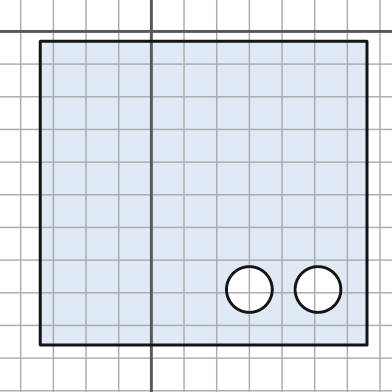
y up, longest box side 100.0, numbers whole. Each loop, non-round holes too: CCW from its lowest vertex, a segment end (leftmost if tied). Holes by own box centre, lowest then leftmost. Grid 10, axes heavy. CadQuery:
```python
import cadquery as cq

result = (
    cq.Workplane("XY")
    .moveTo(-34.0, -96.0)
    .lineTo(66.0, -96.0)
    .lineTo(66.0, -3.0)
    .lineTo(-34.0, -3.0)
    .close()
    .moveTo(30.0, -79.0)
    .circle(7.0)
    .moveTo(51.0, -79.0)
    .circle(7.0)
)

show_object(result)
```